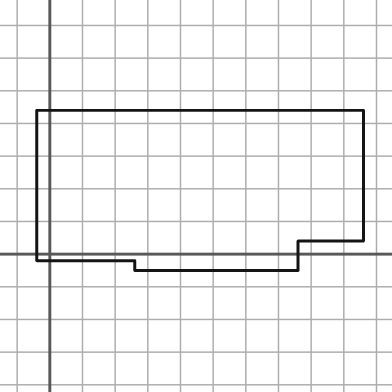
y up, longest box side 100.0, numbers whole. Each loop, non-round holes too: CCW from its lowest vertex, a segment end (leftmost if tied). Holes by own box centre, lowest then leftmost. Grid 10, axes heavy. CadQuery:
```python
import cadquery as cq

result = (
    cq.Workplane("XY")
    .moveTo(26.0, -5.0)
    .lineTo(76.0, -5.0)
    .lineTo(76.0, 4.0)
    .lineTo(96.0, 4.0)
    .lineTo(96.0, 44.0)
    .lineTo(-4.0, 44.0)
    .lineTo(-4.0, -2.0)
    .lineTo(26.0, -2.0)
    .close()
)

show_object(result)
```